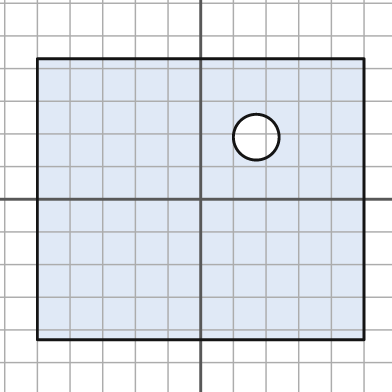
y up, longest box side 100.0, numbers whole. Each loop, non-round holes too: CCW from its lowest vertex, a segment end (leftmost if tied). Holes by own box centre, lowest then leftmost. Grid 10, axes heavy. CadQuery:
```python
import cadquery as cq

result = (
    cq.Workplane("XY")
    .moveTo(-50.0, -43.0)
    .lineTo(50.0, -43.0)
    .lineTo(50.0, 43.0)
    .lineTo(-50.0, 43.0)
    .close()
    .moveTo(17.0, 19.0)
    .circle(7.0)
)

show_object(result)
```